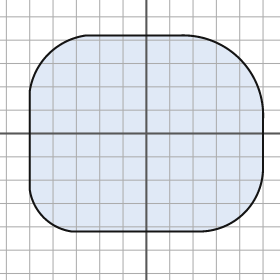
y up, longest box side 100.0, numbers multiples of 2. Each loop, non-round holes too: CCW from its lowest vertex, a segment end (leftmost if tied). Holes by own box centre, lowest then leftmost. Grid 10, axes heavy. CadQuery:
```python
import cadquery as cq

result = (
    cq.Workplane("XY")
    .moveTo(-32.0, -42.0)
    .lineTo(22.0, -42.0)
    .threePointArc((42.0, -34.0), (50.0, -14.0))
    .lineTo(50.0, 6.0)
    .threePointArc((40.0, 32.0), (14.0, 42.0))
    .lineTo(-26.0, 42.0)
    .threePointArc((-42.0, 34.0), (-50.0, 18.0))
    .lineTo(-50.0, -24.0)
    .threePointArc((-44.0, -36.0), (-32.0, -42.0))
    .close()
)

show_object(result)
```